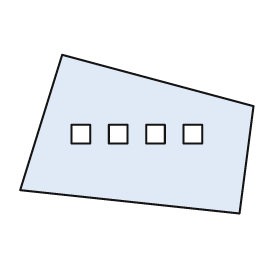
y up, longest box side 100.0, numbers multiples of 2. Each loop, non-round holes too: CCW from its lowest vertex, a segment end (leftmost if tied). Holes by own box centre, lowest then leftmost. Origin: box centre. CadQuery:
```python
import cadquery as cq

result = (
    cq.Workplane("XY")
    .moveTo(44.0, -34.0)
    .lineTo(50.0, 12.0)
    .lineTo(-32.0, 34.0)
    .lineTo(-50.0, -24.0)
    .close()
    .moveTo(-28.0, -4.0)
    .lineTo(-20.0, -4.0)
    .lineTo(-20.0, 4.0)
    .lineTo(-28.0, 4.0)
    .close()
    .moveTo(-12.0, -4.0)
    .lineTo(-4.0, -4.0)
    .lineTo(-4.0, 4.0)
    .lineTo(-12.0, 4.0)
    .close()
    .moveTo(4.0, -4.0)
    .lineTo(12.0, -4.0)
    .lineTo(12.0, 4.0)
    .lineTo(4.0, 4.0)
    .close()
    .moveTo(20.0, -4.0)
    .lineTo(28.0, -4.0)
    .lineTo(28.0, 4.0)
    .lineTo(20.0, 4.0)
    .close()
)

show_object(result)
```